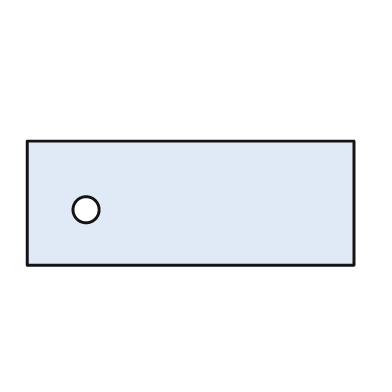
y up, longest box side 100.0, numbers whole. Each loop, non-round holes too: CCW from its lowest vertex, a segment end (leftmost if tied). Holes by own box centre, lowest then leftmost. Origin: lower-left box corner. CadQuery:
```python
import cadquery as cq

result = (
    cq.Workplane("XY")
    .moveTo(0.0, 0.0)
    .lineTo(100.0, 0.0)
    .lineTo(100.0, 38.0)
    .lineTo(0.0, 38.0)
    .close()
    .moveTo(18.0, 17.0)
    .circle(4.0)
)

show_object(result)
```